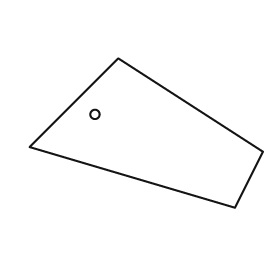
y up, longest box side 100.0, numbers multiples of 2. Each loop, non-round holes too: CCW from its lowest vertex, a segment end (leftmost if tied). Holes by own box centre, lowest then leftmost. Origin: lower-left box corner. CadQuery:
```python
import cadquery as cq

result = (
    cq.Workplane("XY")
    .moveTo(88.0, 0.0)
    .lineTo(100.0, 24.0)
    .lineTo(38.0, 64.0)
    .lineTo(0.0, 26.0)
    .close()
    .moveTo(28.0, 40.0)
    .circle(2.0)
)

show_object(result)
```